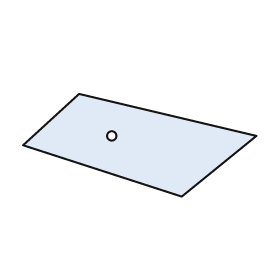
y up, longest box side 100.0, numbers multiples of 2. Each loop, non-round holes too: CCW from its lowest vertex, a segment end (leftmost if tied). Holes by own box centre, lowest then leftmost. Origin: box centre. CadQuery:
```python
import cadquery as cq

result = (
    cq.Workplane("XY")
    .moveTo(18.0, -22.0)
    .lineTo(50.0, 4.0)
    .lineTo(-26.0, 22.0)
    .lineTo(-50.0, 0.0)
    .close()
    .moveTo(-12.0, 4.0)
    .circle(2.0)
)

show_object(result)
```